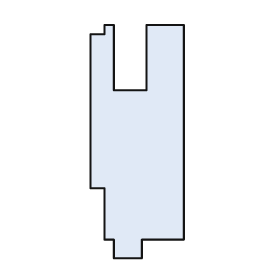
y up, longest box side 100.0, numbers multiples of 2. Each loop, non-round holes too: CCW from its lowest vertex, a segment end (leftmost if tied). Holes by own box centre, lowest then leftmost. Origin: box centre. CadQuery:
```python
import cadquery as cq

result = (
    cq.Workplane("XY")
    .moveTo(-10.0, -50.0)
    .lineTo(2.0, -50.0)
    .lineTo(2.0, -42.0)
    .lineTo(20.0, -42.0)
    .lineTo(20.0, 50.0)
    .lineTo(4.0, 50.0)
    .lineTo(4.0, 22.0)
    .lineTo(-10.0, 22.0)
    .lineTo(-10.0, 50.0)
    .lineTo(-14.0, 50.0)
    .lineTo(-14.0, 46.0)
    .lineTo(-20.0, 46.0)
    .lineTo(-20.0, -20.0)
    .lineTo(-14.0, -20.0)
    .lineTo(-14.0, -42.0)
    .lineTo(-10.0, -42.0)
    .close()
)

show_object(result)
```